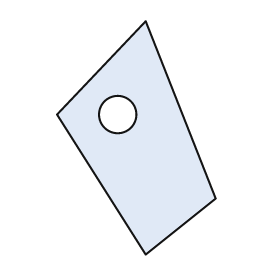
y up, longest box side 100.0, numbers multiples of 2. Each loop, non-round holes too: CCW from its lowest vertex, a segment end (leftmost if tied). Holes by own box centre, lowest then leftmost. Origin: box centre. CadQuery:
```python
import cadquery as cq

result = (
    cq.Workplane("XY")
    .moveTo(4.0, -50.0)
    .lineTo(34.0, -26.0)
    .lineTo(4.0, 50.0)
    .lineTo(-34.0, 10.0)
    .close()
    .moveTo(-8.0, 10.0)
    .circle(8.0)
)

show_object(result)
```